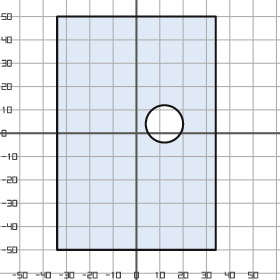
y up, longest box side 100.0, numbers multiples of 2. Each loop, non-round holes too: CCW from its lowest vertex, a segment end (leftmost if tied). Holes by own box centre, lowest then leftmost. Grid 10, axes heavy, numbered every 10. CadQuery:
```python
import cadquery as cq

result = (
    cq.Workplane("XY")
    .moveTo(-34.0, -50.0)
    .lineTo(34.0, -50.0)
    .lineTo(34.0, 50.0)
    .lineTo(-34.0, 50.0)
    .close()
    .moveTo(12.0, 4.0)
    .circle(8.0)
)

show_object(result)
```